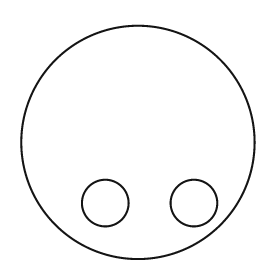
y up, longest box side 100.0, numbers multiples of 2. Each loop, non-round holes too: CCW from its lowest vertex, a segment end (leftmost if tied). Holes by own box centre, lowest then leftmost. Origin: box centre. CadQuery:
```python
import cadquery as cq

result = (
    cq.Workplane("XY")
    .moveTo(0.0, 0.0)
    .circle(50.0)
    .moveTo(-14.0, -26.0)
    .circle(10.0)
    .moveTo(24.0, -26.0)
    .circle(10.0)
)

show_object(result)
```